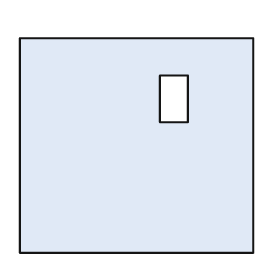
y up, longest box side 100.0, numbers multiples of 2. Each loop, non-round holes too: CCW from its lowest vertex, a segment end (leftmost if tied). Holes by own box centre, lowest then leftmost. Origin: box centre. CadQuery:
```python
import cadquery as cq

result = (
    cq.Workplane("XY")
    .moveTo(-50.0, -46.0)
    .lineTo(50.0, -46.0)
    .lineTo(50.0, 46.0)
    .lineTo(-50.0, 46.0)
    .close()
    .moveTo(10.0, 10.0)
    .lineTo(22.0, 10.0)
    .lineTo(22.0, 30.0)
    .lineTo(10.0, 30.0)
    .close()
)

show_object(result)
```